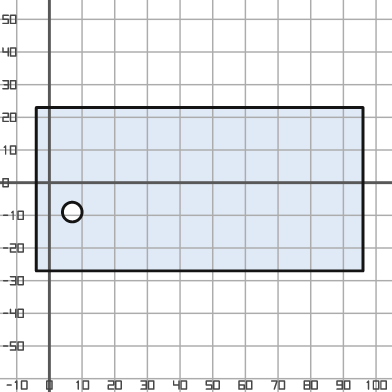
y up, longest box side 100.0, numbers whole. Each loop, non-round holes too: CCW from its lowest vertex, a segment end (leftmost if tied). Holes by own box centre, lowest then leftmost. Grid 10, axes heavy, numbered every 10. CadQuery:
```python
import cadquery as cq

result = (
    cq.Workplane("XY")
    .moveTo(-4.0, -27.0)
    .lineTo(96.0, -27.0)
    .lineTo(96.0, 23.0)
    .lineTo(-4.0, 23.0)
    .close()
    .moveTo(7.0, -9.0)
    .circle(3.0)
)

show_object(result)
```